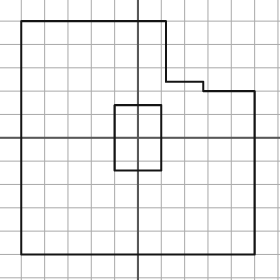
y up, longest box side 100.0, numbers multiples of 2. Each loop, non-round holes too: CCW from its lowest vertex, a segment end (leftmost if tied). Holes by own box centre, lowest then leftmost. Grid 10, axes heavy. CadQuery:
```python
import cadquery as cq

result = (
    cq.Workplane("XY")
    .moveTo(-50.0, -50.0)
    .lineTo(50.0, -50.0)
    .lineTo(50.0, 20.0)
    .lineTo(28.0, 20.0)
    .lineTo(28.0, 24.0)
    .lineTo(12.0, 24.0)
    .lineTo(12.0, 50.0)
    .lineTo(-50.0, 50.0)
    .close()
    .moveTo(-10.0, -14.0)
    .lineTo(10.0, -14.0)
    .lineTo(10.0, 14.0)
    .lineTo(-10.0, 14.0)
    .close()
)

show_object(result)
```